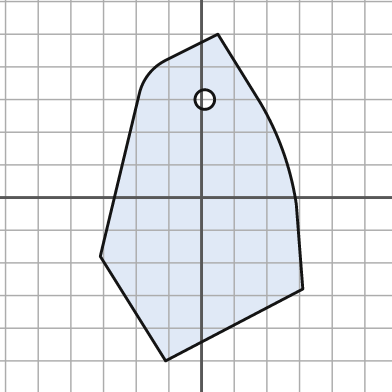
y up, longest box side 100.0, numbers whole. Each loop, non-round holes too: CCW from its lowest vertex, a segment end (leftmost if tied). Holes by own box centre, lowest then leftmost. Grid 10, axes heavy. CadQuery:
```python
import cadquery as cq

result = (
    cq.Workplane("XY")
    .moveTo(-11.0, -50.0)
    .lineTo(31.0, -28.0)
    .lineTo(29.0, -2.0)
    .threePointArc((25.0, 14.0), (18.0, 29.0))
    .lineTo(5.0, 50.0)
    .lineTo(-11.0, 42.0)
    .threePointArc((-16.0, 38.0), (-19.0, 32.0))
    .lineTo(-31.0, -18.0)
    .close()
    .moveTo(1.0, 30.0)
    .circle(3.0)
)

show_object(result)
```